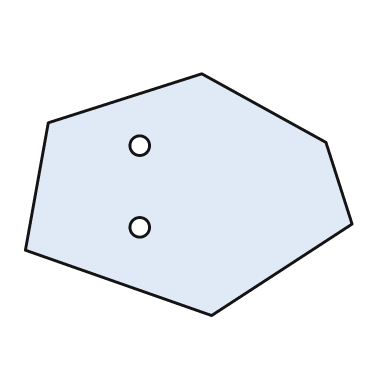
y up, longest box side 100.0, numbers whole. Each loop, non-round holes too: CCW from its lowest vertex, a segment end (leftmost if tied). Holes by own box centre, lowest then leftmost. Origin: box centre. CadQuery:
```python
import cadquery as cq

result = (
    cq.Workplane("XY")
    .moveTo(7.0, -37.0)
    .lineTo(50.0, -9.0)
    .lineTo(42.0, 16.0)
    .lineTo(4.0, 37.0)
    .lineTo(-43.0, 22.0)
    .lineTo(-50.0, -17.0)
    .close()
    .moveTo(-15.0, -10.0)
    .circle(3.0)
    .moveTo(-15.0, 15.0)
    .circle(3.0)
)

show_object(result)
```